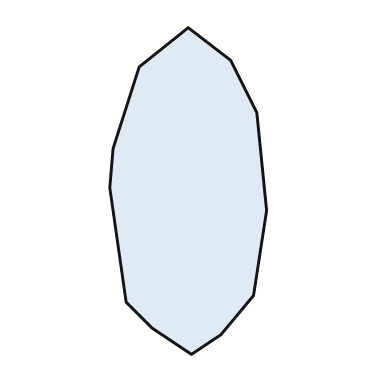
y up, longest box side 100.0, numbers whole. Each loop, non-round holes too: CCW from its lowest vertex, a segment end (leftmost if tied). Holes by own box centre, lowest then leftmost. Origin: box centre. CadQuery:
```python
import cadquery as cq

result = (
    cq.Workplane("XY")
    .moveTo(1.0, -50.0)
    .lineTo(10.0, -44.0)
    .lineTo(20.0, -32.0)
    .lineTo(24.0, -6.0)
    .lineTo(21.0, 24.0)
    .lineTo(13.0, 40.0)
    .lineTo(0.0, 50.0)
    .lineTo(-15.0, 38.0)
    .lineTo(-23.0, 13.0)
    .lineTo(-24.0, 1.0)
    .lineTo(-19.0, -34.0)
    .lineTo(-11.0, -42.0)
    .close()
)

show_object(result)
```